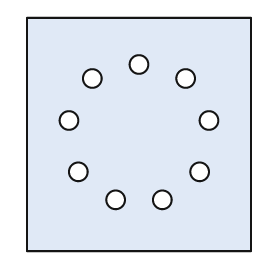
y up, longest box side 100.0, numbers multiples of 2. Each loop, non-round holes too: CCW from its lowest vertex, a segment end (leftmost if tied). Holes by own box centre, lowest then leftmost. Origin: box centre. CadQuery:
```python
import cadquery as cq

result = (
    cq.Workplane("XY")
    .moveTo(-48.0, -50.0)
    .lineTo(48.0, -50.0)
    .lineTo(48.0, 50.0)
    .lineTo(-48.0, 50.0)
    .close()
    .moveTo(-10.0, -28.0)
    .circle(4.0)
    .moveTo(10.0, -28.0)
    .circle(4.0)
    .moveTo(-26.0, -16.0)
    .circle(4.0)
    .moveTo(26.0, -16.0)
    .circle(4.0)
    .moveTo(-30.0, 6.0)
    .circle(4.0)
    .moveTo(30.0, 6.0)
    .circle(4.0)
    .moveTo(-20.0, 24.0)
    .circle(4.0)
    .moveTo(20.0, 24.0)
    .circle(4.0)
    .moveTo(0.0, 30.0)
    .circle(4.0)
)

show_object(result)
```